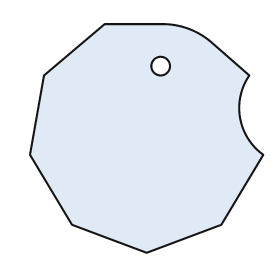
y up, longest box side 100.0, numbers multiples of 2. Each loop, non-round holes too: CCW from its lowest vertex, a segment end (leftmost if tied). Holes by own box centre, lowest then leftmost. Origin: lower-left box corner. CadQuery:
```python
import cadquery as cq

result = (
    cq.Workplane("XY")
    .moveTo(50.0, 0.0)
    .lineTo(82.0, 12.0)
    .lineTo(100.0, 42.0)
    .threePointArc((90.0, 58.0), (94.0, 76.0))
    .lineTo(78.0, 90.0)
    .threePointArc((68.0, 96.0), (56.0, 98.0))
    .lineTo(32.0, 98.0)
    .lineTo(6.0, 76.0)
    .lineTo(0.0, 42.0)
    .lineTo(18.0, 12.0)
    .close()
    .moveTo(56.0, 80.0)
    .circle(4.0)
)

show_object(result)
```